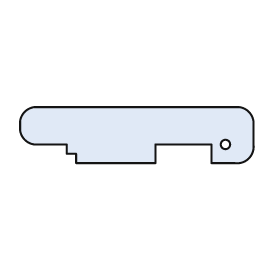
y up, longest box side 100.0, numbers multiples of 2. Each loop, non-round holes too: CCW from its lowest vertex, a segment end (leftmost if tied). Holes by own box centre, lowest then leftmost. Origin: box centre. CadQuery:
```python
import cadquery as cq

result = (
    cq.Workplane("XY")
    .moveTo(-26.0, -12.0)
    .lineTo(8.0, -12.0)
    .lineTo(8.0, -4.0)
    .lineTo(32.0, -4.0)
    .lineTo(32.0, -12.0)
    .lineTo(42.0, -12.0)
    .threePointArc((48.0, -10.0), (50.0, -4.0))
    .lineTo(50.0, 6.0)
    .threePointArc((48.0, 10.0), (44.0, 12.0))
    .lineTo(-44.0, 12.0)
    .threePointArc((-48.0, 10.0), (-50.0, 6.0))
    .lineTo(-50.0, 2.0)
    .threePointArc((-48.0, -2.0), (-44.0, -4.0))
    .lineTo(-30.0, -4.0)
    .lineTo(-30.0, -8.0)
    .lineTo(-26.0, -8.0)
    .close()
    .moveTo(38.0, -4.0)
    .circle(2.0)
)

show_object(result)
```